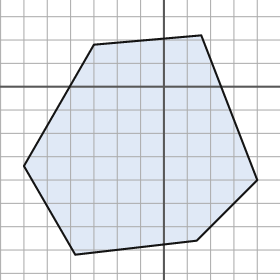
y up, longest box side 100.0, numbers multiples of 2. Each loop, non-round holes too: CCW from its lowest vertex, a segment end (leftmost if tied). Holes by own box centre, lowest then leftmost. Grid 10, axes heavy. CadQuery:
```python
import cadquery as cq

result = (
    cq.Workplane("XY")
    .moveTo(-38.0, -72.0)
    .lineTo(14.0, -66.0)
    .lineTo(40.0, -40.0)
    .lineTo(16.0, 22.0)
    .lineTo(-30.0, 18.0)
    .lineTo(-60.0, -34.0)
    .close()
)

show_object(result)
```